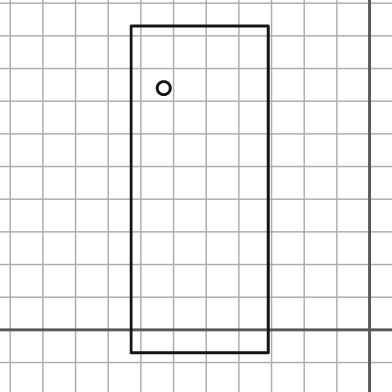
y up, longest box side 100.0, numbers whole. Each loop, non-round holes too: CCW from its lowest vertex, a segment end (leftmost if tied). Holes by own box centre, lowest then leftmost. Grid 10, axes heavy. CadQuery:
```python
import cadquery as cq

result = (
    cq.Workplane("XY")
    .moveTo(-73.0, -7.0)
    .lineTo(-31.0, -7.0)
    .lineTo(-31.0, 93.0)
    .lineTo(-73.0, 93.0)
    .close()
    .moveTo(-63.0, 74.0)
    .circle(2.0)
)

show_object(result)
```